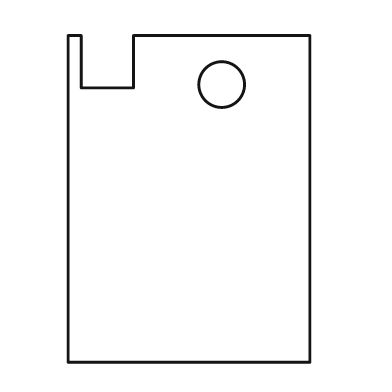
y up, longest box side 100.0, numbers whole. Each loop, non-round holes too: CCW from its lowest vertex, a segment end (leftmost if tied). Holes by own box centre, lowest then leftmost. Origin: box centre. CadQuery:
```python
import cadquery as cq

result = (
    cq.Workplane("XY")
    .moveTo(-37.0, -50.0)
    .lineTo(37.0, -50.0)
    .lineTo(37.0, 50.0)
    .lineTo(-17.0, 50.0)
    .lineTo(-17.0, 34.0)
    .lineTo(-33.0, 34.0)
    .lineTo(-33.0, 50.0)
    .lineTo(-37.0, 50.0)
    .close()
    .moveTo(10.0, 35.0)
    .circle(7.0)
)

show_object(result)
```